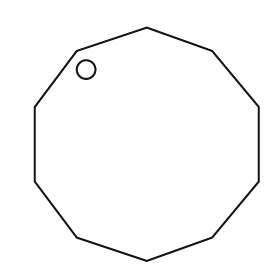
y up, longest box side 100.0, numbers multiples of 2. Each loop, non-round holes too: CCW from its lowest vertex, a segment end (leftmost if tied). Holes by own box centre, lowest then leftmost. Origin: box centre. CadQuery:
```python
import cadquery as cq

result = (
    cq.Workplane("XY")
    .moveTo(0.0, -50.0)
    .lineTo(28.0, -40.0)
    .lineTo(48.0, -16.0)
    .lineTo(48.0, 16.0)
    .lineTo(28.0, 40.0)
    .lineTo(0.0, 50.0)
    .lineTo(-30.0, 40.0)
    .lineTo(-48.0, 16.0)
    .lineTo(-48.0, -16.0)
    .lineTo(-30.0, -40.0)
    .close()
    .moveTo(-26.0, 32.0)
    .circle(4.0)
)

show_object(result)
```